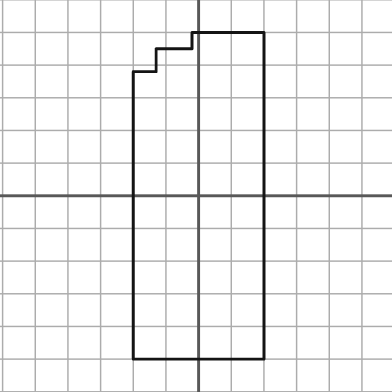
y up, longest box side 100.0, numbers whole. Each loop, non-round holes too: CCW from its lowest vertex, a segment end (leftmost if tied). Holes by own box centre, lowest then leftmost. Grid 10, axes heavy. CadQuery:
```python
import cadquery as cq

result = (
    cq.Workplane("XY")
    .moveTo(-20.0, -50.0)
    .lineTo(20.0, -50.0)
    .lineTo(20.0, 50.0)
    .lineTo(-2.0, 50.0)
    .lineTo(-2.0, 45.0)
    .lineTo(-13.0, 45.0)
    .lineTo(-13.0, 38.0)
    .lineTo(-20.0, 38.0)
    .close()
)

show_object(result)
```